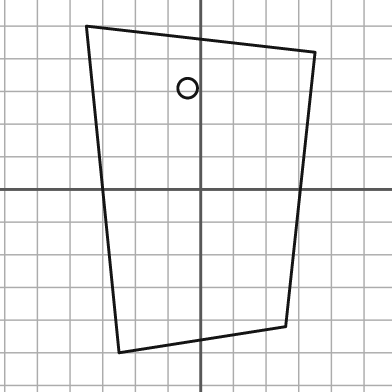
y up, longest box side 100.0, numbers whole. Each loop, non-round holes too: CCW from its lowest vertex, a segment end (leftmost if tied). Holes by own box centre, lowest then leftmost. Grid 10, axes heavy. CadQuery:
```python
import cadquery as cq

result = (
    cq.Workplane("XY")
    .moveTo(-25.0, -50.0)
    .lineTo(26.0, -42.0)
    .lineTo(35.0, 42.0)
    .lineTo(-35.0, 50.0)
    .close()
    .moveTo(-4.0, 31.0)
    .circle(3.0)
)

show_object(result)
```